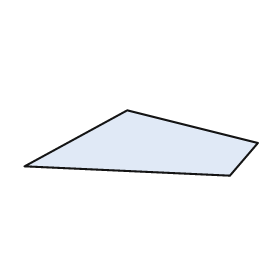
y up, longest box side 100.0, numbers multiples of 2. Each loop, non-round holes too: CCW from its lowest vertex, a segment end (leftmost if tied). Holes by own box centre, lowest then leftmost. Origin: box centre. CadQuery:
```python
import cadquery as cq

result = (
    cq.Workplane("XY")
    .moveTo(38.0, -14.0)
    .lineTo(50.0, 0.0)
    .lineTo(-6.0, 14.0)
    .lineTo(-50.0, -10.0)
    .close()
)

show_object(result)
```